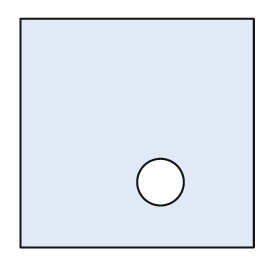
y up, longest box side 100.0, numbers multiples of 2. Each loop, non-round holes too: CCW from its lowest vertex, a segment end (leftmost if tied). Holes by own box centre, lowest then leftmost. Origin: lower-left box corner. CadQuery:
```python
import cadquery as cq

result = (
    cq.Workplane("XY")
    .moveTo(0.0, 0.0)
    .lineTo(100.0, 0.0)
    .lineTo(100.0, 98.0)
    .lineTo(0.0, 98.0)
    .close()
    .moveTo(60.0, 28.0)
    .circle(10.0)
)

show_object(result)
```